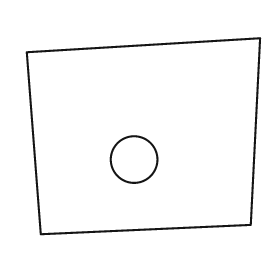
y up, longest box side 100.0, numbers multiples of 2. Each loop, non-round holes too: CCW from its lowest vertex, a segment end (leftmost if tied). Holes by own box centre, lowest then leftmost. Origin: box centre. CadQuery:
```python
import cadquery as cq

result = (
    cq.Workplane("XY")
    .moveTo(-44.0, -42.0)
    .lineTo(46.0, -38.0)
    .lineTo(50.0, 42.0)
    .lineTo(-50.0, 36.0)
    .close()
    .moveTo(-4.0, -10.0)
    .circle(10.0)
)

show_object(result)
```